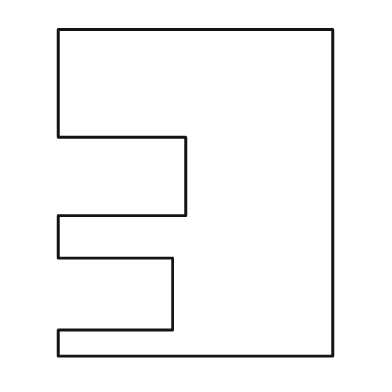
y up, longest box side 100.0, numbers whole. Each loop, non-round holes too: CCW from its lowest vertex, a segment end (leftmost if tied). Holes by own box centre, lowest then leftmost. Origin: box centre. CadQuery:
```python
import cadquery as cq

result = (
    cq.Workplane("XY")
    .moveTo(-42.0, -50.0)
    .lineTo(42.0, -50.0)
    .lineTo(42.0, 50.0)
    .lineTo(-42.0, 50.0)
    .lineTo(-42.0, 17.0)
    .lineTo(-3.0, 17.0)
    .lineTo(-3.0, -7.0)
    .lineTo(-42.0, -7.0)
    .lineTo(-42.0, -20.0)
    .lineTo(-7.0, -20.0)
    .lineTo(-7.0, -42.0)
    .lineTo(-42.0, -42.0)
    .close()
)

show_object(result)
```